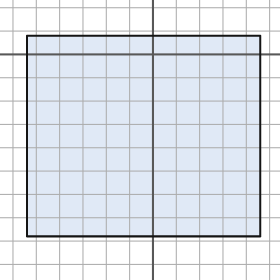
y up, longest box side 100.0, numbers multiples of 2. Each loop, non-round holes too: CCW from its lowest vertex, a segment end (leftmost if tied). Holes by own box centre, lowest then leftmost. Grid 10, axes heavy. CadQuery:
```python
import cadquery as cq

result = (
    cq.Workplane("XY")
    .moveTo(-54.0, -78.0)
    .lineTo(46.0, -78.0)
    .lineTo(46.0, 8.0)
    .lineTo(-54.0, 8.0)
    .close()
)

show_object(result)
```